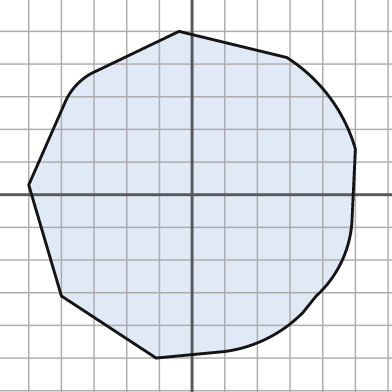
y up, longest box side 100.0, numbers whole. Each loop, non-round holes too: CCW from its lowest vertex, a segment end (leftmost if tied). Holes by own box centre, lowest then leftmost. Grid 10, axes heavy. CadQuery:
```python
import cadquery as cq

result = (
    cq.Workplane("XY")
    .moveTo(-11.0, -50.0)
    .lineTo(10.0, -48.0)
    .threePointArc((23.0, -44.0), (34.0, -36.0))
    .lineTo(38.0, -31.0)
    .threePointArc((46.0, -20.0), (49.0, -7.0))
    .lineTo(50.0, 14.0)
    .threePointArc((42.0, 30.0), (29.0, 42.0))
    .lineTo(-4.0, 50.0)
    .lineTo(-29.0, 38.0)
    .threePointArc((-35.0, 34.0), (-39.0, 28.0))
    .lineTo(-50.0, 3.0)
    .lineTo(-40.0, -31.0)
    .close()
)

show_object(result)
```